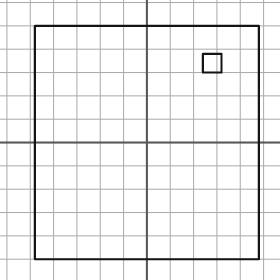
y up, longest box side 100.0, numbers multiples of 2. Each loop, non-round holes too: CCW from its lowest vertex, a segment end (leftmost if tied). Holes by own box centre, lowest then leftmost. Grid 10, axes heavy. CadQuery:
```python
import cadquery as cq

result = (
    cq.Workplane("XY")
    .moveTo(-48.0, -50.0)
    .lineTo(48.0, -50.0)
    .lineTo(48.0, 50.0)
    .lineTo(-48.0, 50.0)
    .close()
    .moveTo(24.0, 30.0)
    .lineTo(32.0, 30.0)
    .lineTo(32.0, 38.0)
    .lineTo(24.0, 38.0)
    .close()
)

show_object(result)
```